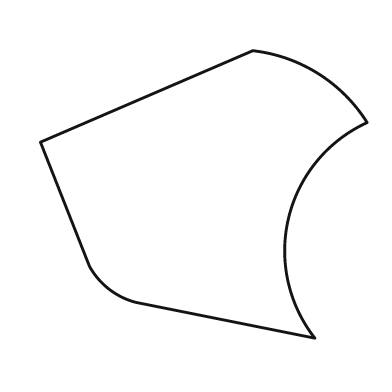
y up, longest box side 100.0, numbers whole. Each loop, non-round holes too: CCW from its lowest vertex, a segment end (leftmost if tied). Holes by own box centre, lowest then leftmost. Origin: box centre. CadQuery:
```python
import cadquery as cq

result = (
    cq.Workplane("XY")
    .moveTo(34.0, -44.0)
    .threePointArc((26.0, -7.0), (50.0, 22.0))
    .threePointArc((35.0, 37.0), (15.0, 44.0))
    .lineTo(-50.0, 16.0)
    .lineTo(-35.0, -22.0)
    .threePointArc((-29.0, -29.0), (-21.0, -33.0))
    .close()
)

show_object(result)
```